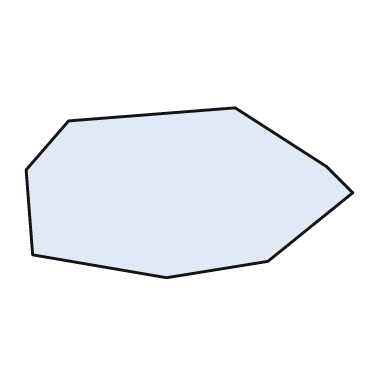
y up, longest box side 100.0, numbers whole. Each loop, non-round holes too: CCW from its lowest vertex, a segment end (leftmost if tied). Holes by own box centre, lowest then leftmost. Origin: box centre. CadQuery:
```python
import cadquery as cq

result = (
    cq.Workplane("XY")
    .moveTo(-7.0, -26.0)
    .lineTo(24.0, -21.0)
    .lineTo(50.0, 0.0)
    .lineTo(42.0, 8.0)
    .lineTo(14.0, 26.0)
    .lineTo(-37.0, 22.0)
    .lineTo(-50.0, 7.0)
    .lineTo(-48.0, -19.0)
    .close()
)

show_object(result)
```